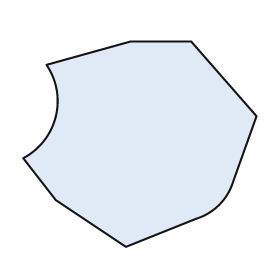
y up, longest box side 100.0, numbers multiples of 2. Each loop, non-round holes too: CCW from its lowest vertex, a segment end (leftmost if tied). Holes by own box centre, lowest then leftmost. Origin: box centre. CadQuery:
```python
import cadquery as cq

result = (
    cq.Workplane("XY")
    .moveTo(-6.0, -44.0)
    .lineTo(24.0, -32.0)
    .threePointArc((34.0, -26.0), (40.0, -16.0))
    .lineTo(50.0, 12.0)
    .lineTo(22.0, 44.0)
    .lineTo(-4.0, 44.0)
    .lineTo(-40.0, 34.0)
    .threePointArc((-36.0, 12.0), (-50.0, -6.0))
    .lineTo(-36.0, -24.0)
    .close()
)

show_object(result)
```